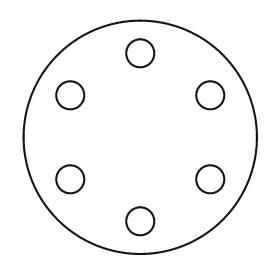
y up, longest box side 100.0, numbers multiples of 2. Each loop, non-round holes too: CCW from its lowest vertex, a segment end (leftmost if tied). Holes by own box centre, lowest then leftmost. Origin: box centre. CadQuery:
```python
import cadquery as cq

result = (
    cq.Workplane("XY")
    .moveTo(0.0, 0.0)
    .circle(50.0)
    .moveTo(0.0, -36.0)
    .circle(6.0)
    .moveTo(-30.0, -18.0)
    .circle(6.0)
    .moveTo(30.0, -18.0)
    .circle(6.0)
    .moveTo(-30.0, 18.0)
    .circle(6.0)
    .moveTo(30.0, 18.0)
    .circle(6.0)
    .moveTo(0.0, 36.0)
    .circle(6.0)
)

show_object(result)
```